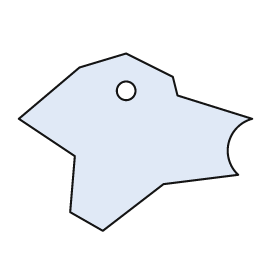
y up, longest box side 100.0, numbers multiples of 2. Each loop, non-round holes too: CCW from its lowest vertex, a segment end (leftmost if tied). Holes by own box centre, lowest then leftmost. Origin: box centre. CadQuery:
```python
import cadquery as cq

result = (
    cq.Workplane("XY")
    .moveTo(-14.0, -38.0)
    .lineTo(12.0, -18.0)
    .lineTo(44.0, -14.0)
    .threePointArc((40.0, 0.0), (50.0, 10.0))
    .lineTo(18.0, 20.0)
    .lineTo(16.0, 28.0)
    .lineTo(-4.0, 38.0)
    .lineTo(-24.0, 32.0)
    .lineTo(-50.0, 10.0)
    .lineTo(-26.0, -6.0)
    .lineTo(-28.0, -30.0)
    .close()
    .moveTo(-4.0, 22.0)
    .circle(4.0)
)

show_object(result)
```